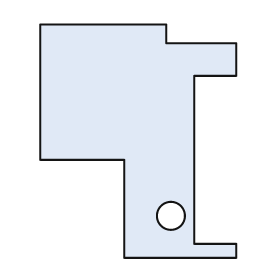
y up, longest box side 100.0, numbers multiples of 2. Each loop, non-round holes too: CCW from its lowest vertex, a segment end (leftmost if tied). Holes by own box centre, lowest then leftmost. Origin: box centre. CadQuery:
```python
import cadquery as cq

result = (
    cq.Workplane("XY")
    .moveTo(-6.0, -50.0)
    .lineTo(42.0, -50.0)
    .lineTo(42.0, -44.0)
    .lineTo(24.0, -44.0)
    .lineTo(24.0, 28.0)
    .lineTo(42.0, 28.0)
    .lineTo(42.0, 42.0)
    .lineTo(12.0, 42.0)
    .lineTo(12.0, 50.0)
    .lineTo(-42.0, 50.0)
    .lineTo(-42.0, -8.0)
    .lineTo(-6.0, -8.0)
    .close()
    .moveTo(14.0, -32.0)
    .circle(6.0)
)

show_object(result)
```